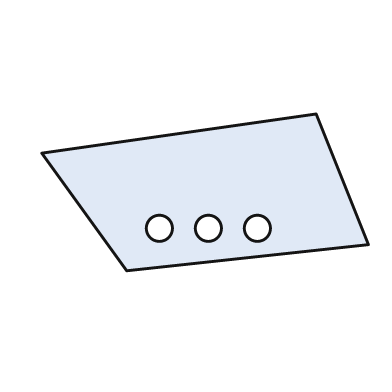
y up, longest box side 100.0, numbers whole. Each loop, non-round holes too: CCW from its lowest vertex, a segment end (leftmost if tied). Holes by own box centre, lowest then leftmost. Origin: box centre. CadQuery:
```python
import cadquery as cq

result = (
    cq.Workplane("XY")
    .moveTo(-24.0, -24.0)
    .lineTo(50.0, -16.0)
    .lineTo(34.0, 24.0)
    .lineTo(-50.0, 12.0)
    .close()
    .moveTo(-14.0, -11.0)
    .circle(4.0)
    .moveTo(1.0, -11.0)
    .circle(4.0)
    .moveTo(16.0, -11.0)
    .circle(4.0)
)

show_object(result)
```